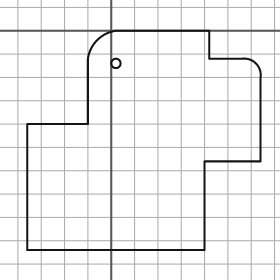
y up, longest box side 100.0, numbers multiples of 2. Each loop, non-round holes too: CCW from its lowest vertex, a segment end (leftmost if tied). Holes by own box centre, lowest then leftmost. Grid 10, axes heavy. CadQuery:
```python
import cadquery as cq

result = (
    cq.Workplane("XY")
    .moveTo(-36.0, -94.0)
    .lineTo(40.0, -94.0)
    .lineTo(40.0, -56.0)
    .lineTo(64.0, -56.0)
    .lineTo(64.0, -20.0)
    .threePointArc((62.0, -14.0), (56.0, -12.0))
    .lineTo(42.0, -12.0)
    .lineTo(42.0, 0.0)
    .lineTo(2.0, 0.0)
    .threePointArc((-6.0, -4.0), (-10.0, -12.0))
    .lineTo(-10.0, -40.0)
    .lineTo(-36.0, -40.0)
    .close()
    .moveTo(2.0, -14.0)
    .circle(2.0)
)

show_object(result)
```